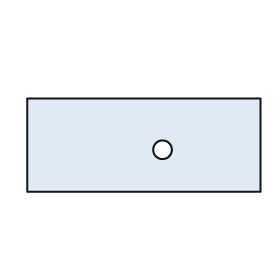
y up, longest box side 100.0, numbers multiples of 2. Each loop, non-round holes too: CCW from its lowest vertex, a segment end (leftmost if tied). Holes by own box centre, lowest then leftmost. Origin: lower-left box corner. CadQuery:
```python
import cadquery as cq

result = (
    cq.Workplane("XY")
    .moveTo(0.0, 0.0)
    .lineTo(100.0, 0.0)
    .lineTo(100.0, 40.0)
    .lineTo(0.0, 40.0)
    .close()
    .moveTo(58.0, 18.0)
    .circle(4.0)
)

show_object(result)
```